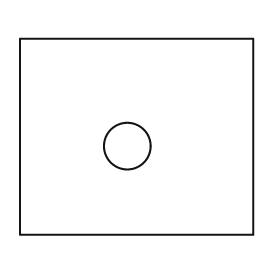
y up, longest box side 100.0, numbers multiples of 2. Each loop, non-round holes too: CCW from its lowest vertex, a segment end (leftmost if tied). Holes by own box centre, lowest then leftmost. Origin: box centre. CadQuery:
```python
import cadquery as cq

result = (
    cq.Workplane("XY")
    .moveTo(-50.0, -42.0)
    .lineTo(50.0, -42.0)
    .lineTo(50.0, 42.0)
    .lineTo(-50.0, 42.0)
    .close()
    .moveTo(-4.0, -4.0)
    .circle(10.0)
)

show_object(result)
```